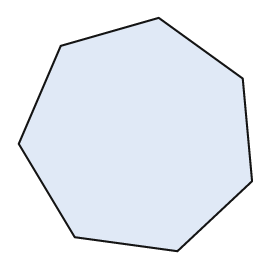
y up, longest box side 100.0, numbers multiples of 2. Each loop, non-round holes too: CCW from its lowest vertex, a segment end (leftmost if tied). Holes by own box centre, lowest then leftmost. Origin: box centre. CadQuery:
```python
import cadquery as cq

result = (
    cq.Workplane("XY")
    .moveTo(18.0, -50.0)
    .lineTo(50.0, -20.0)
    .lineTo(46.0, 24.0)
    .lineTo(10.0, 50.0)
    .lineTo(-32.0, 38.0)
    .lineTo(-50.0, -4.0)
    .lineTo(-26.0, -44.0)
    .close()
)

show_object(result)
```